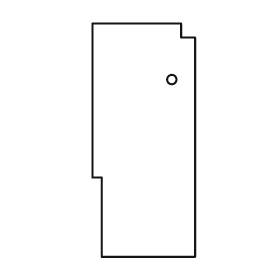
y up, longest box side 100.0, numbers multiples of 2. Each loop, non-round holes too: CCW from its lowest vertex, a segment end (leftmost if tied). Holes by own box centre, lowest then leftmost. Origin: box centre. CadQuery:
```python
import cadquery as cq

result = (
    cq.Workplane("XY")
    .moveTo(-18.0, -50.0)
    .lineTo(22.0, -50.0)
    .lineTo(22.0, 44.0)
    .lineTo(16.0, 44.0)
    .lineTo(16.0, 50.0)
    .lineTo(-22.0, 50.0)
    .lineTo(-22.0, -16.0)
    .lineTo(-18.0, -16.0)
    .close()
    .moveTo(12.0, 26.0)
    .circle(2.0)
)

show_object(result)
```